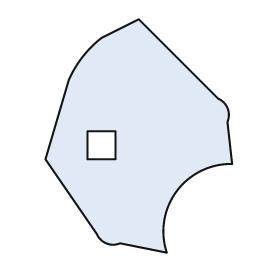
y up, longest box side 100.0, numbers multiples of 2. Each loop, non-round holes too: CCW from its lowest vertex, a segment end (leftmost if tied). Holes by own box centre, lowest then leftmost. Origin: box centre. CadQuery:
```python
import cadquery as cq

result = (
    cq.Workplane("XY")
    .moveTo(12.0, -50.0)
    .threePointArc((16.0, -24.0), (40.0, -12.0))
    .lineTo(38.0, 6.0)
    .threePointArc((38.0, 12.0), (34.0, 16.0))
    .lineTo(0.0, 50.0)
    .lineTo(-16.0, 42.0)
    .threePointArc((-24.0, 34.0), (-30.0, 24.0))
    .lineTo(-40.0, -10.0)
    .lineTo(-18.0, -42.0)
    .threePointArc((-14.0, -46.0), (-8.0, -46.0))
    .close()
    .moveTo(-22.0, -10.0)
    .lineTo(-10.0, -10.0)
    .lineTo(-10.0, 2.0)
    .lineTo(-22.0, 2.0)
    .close()
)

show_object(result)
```